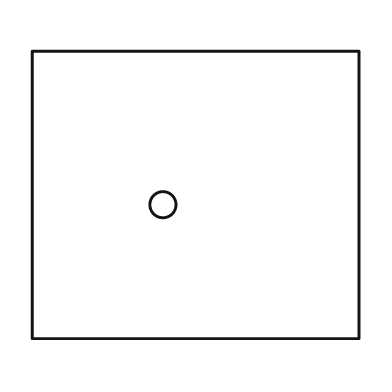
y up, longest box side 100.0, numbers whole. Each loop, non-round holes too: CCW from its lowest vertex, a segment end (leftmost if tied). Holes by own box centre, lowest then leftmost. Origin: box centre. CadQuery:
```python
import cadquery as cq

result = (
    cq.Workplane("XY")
    .moveTo(-50.0, -44.0)
    .lineTo(50.0, -44.0)
    .lineTo(50.0, 44.0)
    .lineTo(-50.0, 44.0)
    .close()
    .moveTo(-10.0, -3.0)
    .circle(4.0)
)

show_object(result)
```